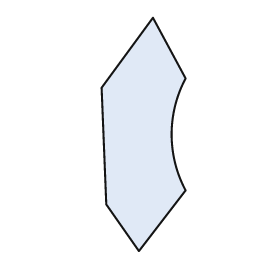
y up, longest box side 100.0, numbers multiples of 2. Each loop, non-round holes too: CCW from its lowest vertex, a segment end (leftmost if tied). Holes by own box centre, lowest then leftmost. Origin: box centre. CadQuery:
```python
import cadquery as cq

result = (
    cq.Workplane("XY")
    .moveTo(-2.0, -50.0)
    .lineTo(18.0, -24.0)
    .threePointArc((12.0, 0.0), (18.0, 24.0))
    .lineTo(4.0, 50.0)
    .lineTo(-18.0, 20.0)
    .lineTo(-16.0, -30.0)
    .close()
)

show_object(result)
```